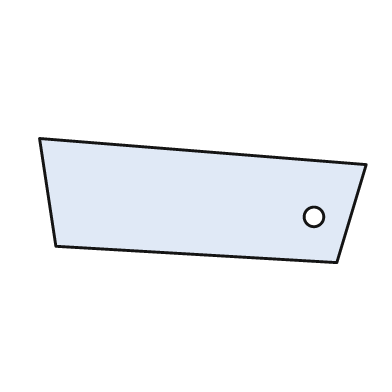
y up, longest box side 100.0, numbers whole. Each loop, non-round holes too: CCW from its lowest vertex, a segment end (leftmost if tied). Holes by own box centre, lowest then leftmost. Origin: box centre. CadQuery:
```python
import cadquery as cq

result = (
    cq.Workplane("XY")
    .moveTo(41.0, -19.0)
    .lineTo(50.0, 11.0)
    .lineTo(-50.0, 19.0)
    .lineTo(-45.0, -14.0)
    .close()
    .moveTo(34.0, -5.0)
    .circle(3.0)
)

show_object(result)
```